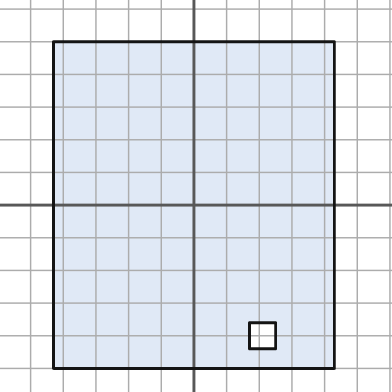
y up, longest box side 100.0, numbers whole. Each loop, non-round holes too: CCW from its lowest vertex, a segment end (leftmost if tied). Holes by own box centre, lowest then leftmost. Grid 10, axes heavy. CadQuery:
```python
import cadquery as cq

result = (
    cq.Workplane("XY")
    .moveTo(-43.0, -50.0)
    .lineTo(43.0, -50.0)
    .lineTo(43.0, 50.0)
    .lineTo(-43.0, 50.0)
    .close()
    .moveTo(17.0, -44.0)
    .lineTo(25.0, -44.0)
    .lineTo(25.0, -36.0)
    .lineTo(17.0, -36.0)
    .close()
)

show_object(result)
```